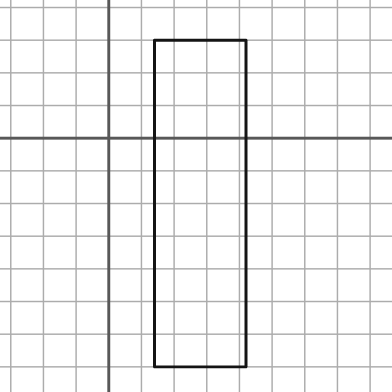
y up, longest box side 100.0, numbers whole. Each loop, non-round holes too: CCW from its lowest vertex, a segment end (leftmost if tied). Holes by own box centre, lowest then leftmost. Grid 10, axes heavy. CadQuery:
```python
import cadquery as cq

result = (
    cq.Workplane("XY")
    .moveTo(14.0, -70.0)
    .lineTo(42.0, -70.0)
    .lineTo(42.0, 30.0)
    .lineTo(14.0, 30.0)
    .close()
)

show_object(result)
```